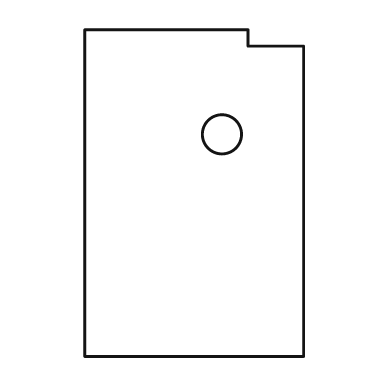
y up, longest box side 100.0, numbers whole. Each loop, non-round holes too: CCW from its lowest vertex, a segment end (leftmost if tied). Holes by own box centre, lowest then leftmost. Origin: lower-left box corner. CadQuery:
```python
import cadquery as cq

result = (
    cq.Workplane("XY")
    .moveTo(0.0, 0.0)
    .lineTo(67.0, 0.0)
    .lineTo(67.0, 95.0)
    .lineTo(50.0, 95.0)
    .lineTo(50.0, 100.0)
    .lineTo(0.0, 100.0)
    .close()
    .moveTo(42.0, 68.0)
    .circle(6.0)
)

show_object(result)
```